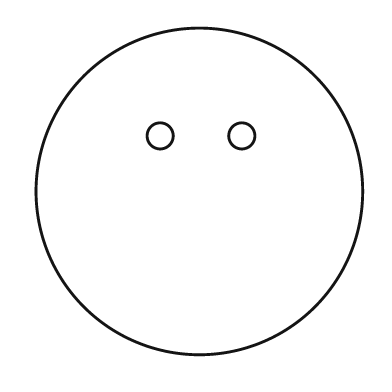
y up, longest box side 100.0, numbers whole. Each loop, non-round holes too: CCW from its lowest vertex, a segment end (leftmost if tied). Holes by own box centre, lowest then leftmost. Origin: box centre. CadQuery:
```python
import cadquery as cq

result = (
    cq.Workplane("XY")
    .moveTo(0.0, 0.0)
    .circle(50.0)
    .moveTo(-12.0, 17.0)
    .circle(4.0)
    .moveTo(13.0, 17.0)
    .circle(4.0)
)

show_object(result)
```